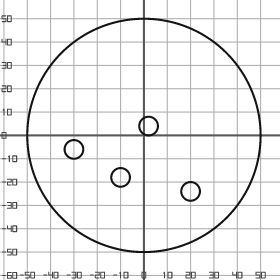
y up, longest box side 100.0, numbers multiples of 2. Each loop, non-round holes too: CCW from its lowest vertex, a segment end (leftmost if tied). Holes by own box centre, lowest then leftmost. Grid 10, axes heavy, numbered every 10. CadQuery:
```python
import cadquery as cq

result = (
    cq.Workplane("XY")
    .moveTo(0.0, 0.0)
    .circle(50.0)
    .moveTo(20.0, -24.0)
    .circle(4.0)
    .moveTo(-10.0, -18.0)
    .circle(4.0)
    .moveTo(-30.0, -6.0)
    .circle(4.0)
    .moveTo(2.0, 4.0)
    .circle(4.0)
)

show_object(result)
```